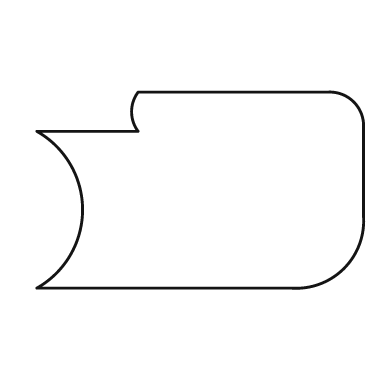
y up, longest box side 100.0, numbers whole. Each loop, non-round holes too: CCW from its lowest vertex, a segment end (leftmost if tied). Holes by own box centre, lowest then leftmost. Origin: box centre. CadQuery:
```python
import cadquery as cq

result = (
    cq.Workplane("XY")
    .moveTo(-50.0, -30.0)
    .lineTo(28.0, -30.0)
    .threePointArc((44.0, -24.0), (50.0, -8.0))
    .lineTo(50.0, 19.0)
    .threePointArc((47.0, 27.0), (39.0, 30.0))
    .lineTo(-19.0, 30.0)
    .threePointArc((-21.0, 24.0), (-19.0, 18.0))
    .lineTo(-50.0, 18.0)
    .threePointArc((-36.0, -6.0), (-50.0, -30.0))
    .close()
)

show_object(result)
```